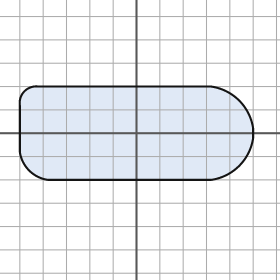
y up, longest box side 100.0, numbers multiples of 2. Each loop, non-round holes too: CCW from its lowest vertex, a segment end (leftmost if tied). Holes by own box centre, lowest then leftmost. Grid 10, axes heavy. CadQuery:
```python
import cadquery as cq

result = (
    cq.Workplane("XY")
    .moveTo(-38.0, -20.0)
    .lineTo(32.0, -20.0)
    .threePointArc((44.0, -14.0), (50.0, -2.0))
    .lineTo(50.0, 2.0)
    .threePointArc((44.0, 14.0), (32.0, 20.0))
    .lineTo(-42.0, 20.0)
    .threePointArc((-48.0, 18.0), (-50.0, 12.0))
    .lineTo(-50.0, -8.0)
    .threePointArc((-46.0, -16.0), (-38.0, -20.0))
    .close()
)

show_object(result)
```